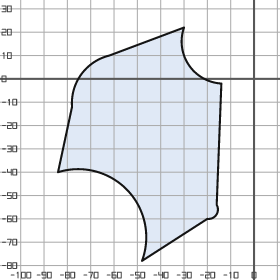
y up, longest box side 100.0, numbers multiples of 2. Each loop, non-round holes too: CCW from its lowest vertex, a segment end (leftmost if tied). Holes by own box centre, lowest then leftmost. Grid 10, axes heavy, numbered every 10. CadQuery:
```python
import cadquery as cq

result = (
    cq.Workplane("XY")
    .moveTo(-48.0, -78.0)
    .lineTo(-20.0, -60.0)
    .threePointArc((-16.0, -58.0), (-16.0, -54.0))
    .lineTo(-14.0, -2.0)
    .threePointArc((-28.0, 6.0), (-30.0, 22.0))
    .lineTo(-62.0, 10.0)
    .threePointArc((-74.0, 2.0), (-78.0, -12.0))
    .lineTo(-84.0, -40.0)
    .threePointArc((-54.0, -48.0), (-48.0, -78.0))
    .close()
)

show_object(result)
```